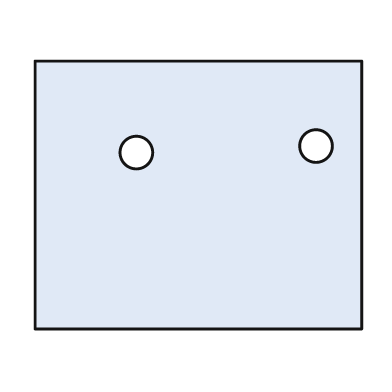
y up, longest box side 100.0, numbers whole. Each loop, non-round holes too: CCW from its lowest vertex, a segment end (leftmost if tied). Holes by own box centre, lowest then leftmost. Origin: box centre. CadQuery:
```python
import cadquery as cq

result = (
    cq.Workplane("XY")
    .moveTo(-50.0, -41.0)
    .lineTo(50.0, -41.0)
    .lineTo(50.0, 41.0)
    .lineTo(-50.0, 41.0)
    .close()
    .moveTo(-19.0, 13.0)
    .circle(5.0)
    .moveTo(36.0, 15.0)
    .circle(5.0)
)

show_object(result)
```